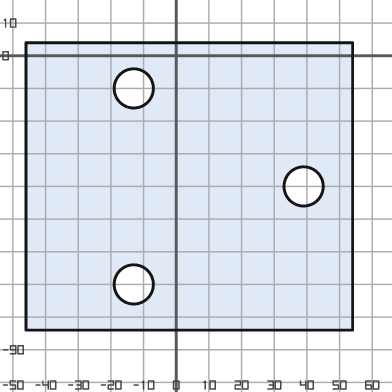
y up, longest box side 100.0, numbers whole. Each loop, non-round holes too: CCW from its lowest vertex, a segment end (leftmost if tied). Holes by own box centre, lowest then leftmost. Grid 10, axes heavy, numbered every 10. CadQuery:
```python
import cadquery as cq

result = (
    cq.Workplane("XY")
    .moveTo(-46.0, -84.0)
    .lineTo(54.0, -84.0)
    .lineTo(54.0, 4.0)
    .lineTo(-46.0, 4.0)
    .close()
    .moveTo(-13.0, -70.0)
    .circle(6.0)
    .moveTo(39.0, -40.0)
    .circle(6.0)
    .moveTo(-13.0, -10.0)
    .circle(6.0)
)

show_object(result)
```